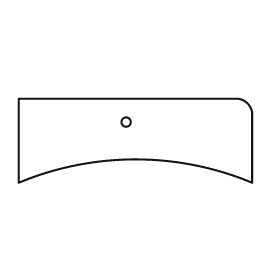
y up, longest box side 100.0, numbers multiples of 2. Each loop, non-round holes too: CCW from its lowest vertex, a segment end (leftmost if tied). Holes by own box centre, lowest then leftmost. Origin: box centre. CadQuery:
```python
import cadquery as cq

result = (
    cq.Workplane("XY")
    .moveTo(-50.0, -18.0)
    .threePointArc((0.0, -8.0), (50.0, -18.0))
    .lineTo(50.0, 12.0)
    .threePointArc((48.0, 16.0), (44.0, 18.0))
    .lineTo(-50.0, 18.0)
    .close()
    .moveTo(-4.0, 8.0)
    .circle(2.0)
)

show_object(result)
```